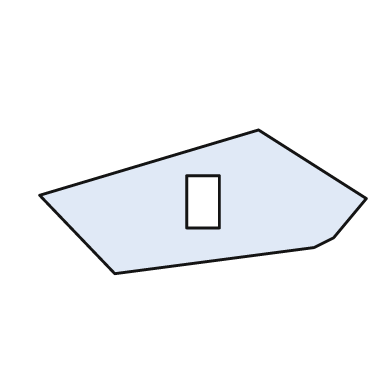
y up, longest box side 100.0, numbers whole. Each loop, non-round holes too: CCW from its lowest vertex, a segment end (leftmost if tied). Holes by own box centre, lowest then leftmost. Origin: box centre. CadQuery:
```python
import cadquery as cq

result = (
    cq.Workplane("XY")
    .moveTo(-27.0, -22.0)
    .lineTo(34.0, -14.0)
    .lineTo(40.0, -11.0)
    .lineTo(50.0, 1.0)
    .lineTo(17.0, 22.0)
    .lineTo(-50.0, 2.0)
    .close()
    .moveTo(-5.0, -8.0)
    .lineTo(5.0, -8.0)
    .lineTo(5.0, 8.0)
    .lineTo(-5.0, 8.0)
    .close()
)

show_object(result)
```